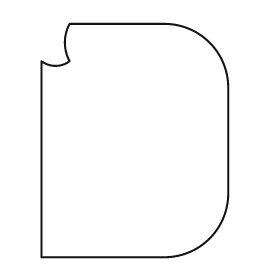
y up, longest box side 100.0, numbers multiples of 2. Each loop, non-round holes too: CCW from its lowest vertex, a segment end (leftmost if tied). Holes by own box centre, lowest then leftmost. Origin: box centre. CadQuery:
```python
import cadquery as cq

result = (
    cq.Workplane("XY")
    .moveTo(-40.0, -50.0)
    .lineTo(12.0, -50.0)
    .threePointArc((32.0, -42.0), (40.0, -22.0))
    .lineTo(40.0, 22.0)
    .threePointArc((32.0, 42.0), (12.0, 50.0))
    .lineTo(-28.0, 50.0)
    .threePointArc((-30.0, 42.0), (-28.0, 34.0))
    .threePointArc((-34.0, 32.0), (-40.0, 34.0))
    .close()
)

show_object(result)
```